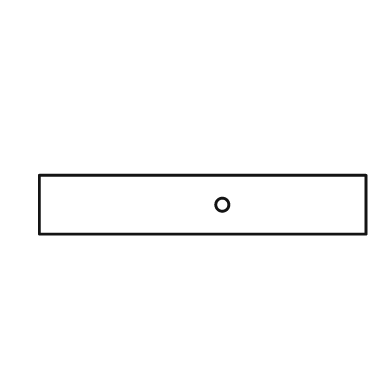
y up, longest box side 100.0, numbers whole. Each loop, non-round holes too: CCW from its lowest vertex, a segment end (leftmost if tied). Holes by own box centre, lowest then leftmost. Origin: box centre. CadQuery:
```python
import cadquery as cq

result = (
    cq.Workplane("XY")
    .moveTo(-50.0, -9.0)
    .lineTo(50.0, -9.0)
    .lineTo(50.0, 9.0)
    .lineTo(-50.0, 9.0)
    .close()
    .moveTo(6.0, 0.0)
    .circle(2.0)
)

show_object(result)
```